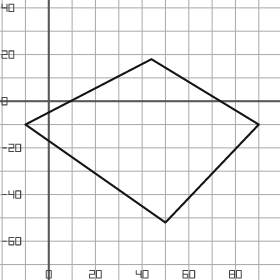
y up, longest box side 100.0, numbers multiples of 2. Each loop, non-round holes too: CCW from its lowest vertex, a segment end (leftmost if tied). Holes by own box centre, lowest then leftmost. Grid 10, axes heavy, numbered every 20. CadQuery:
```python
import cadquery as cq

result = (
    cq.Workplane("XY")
    .moveTo(50.0, -52.0)
    .lineTo(90.0, -10.0)
    .lineTo(44.0, 18.0)
    .lineTo(-10.0, -10.0)
    .close()
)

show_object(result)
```